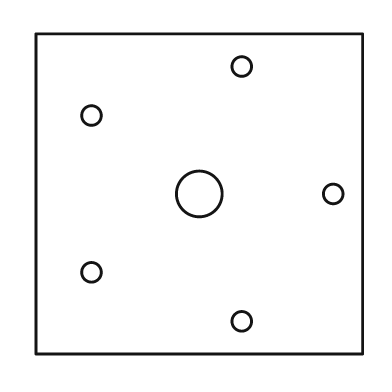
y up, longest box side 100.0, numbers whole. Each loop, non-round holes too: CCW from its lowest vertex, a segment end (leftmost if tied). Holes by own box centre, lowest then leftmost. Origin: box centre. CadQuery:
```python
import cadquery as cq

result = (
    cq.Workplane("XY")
    .moveTo(-50.0, -49.0)
    .lineTo(50.0, -49.0)
    .lineTo(50.0, 49.0)
    .lineTo(-50.0, 49.0)
    .close()
    .moveTo(13.0, -39.0)
    .circle(3.0)
    .moveTo(-33.0, -24.0)
    .circle(3.0)
    .moveTo(0.0, 0.0)
    .circle(7.0)
    .moveTo(41.0, 0.0)
    .circle(3.0)
    .moveTo(-33.0, 24.0)
    .circle(3.0)
    .moveTo(13.0, 39.0)
    .circle(3.0)
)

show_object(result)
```